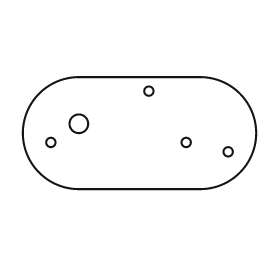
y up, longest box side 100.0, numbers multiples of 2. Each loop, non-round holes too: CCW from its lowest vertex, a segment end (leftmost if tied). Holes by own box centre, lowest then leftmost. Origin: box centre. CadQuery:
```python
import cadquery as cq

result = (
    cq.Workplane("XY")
    .moveTo(-26.0, -24.0)
    .lineTo(26.0, -24.0)
    .threePointArc((50.0, 0.0), (26.0, 24.0))
    .lineTo(-26.0, 24.0)
    .threePointArc((-50.0, 0.0), (-26.0, -24.0))
    .close()
    .moveTo(38.0, -8.0)
    .circle(2.0)
    .moveTo(-38.0, -4.0)
    .circle(2.0)
    .moveTo(20.0, -4.0)
    .circle(2.0)
    .moveTo(-26.0, 4.0)
    .circle(4.0)
    .moveTo(4.0, 18.0)
    .circle(2.0)
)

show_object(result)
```